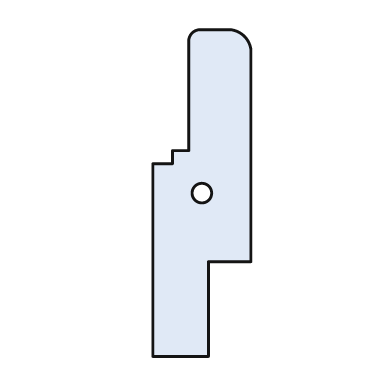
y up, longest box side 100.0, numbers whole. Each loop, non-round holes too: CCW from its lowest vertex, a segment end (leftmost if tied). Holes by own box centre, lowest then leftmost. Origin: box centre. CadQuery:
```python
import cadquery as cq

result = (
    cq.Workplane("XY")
    .moveTo(-15.0, -50.0)
    .lineTo(2.0, -50.0)
    .lineTo(2.0, -21.0)
    .lineTo(15.0, -21.0)
    .lineTo(15.0, 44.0)
    .threePointArc((13.0, 48.0), (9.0, 50.0))
    .lineTo(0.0, 50.0)
    .threePointArc((-3.0, 49.0), (-4.0, 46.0))
    .lineTo(-4.0, 13.0)
    .lineTo(-9.0, 13.0)
    .lineTo(-9.0, 9.0)
    .lineTo(-15.0, 9.0)
    .close()
    .moveTo(0.0, 0.0)
    .circle(3.0)
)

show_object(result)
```